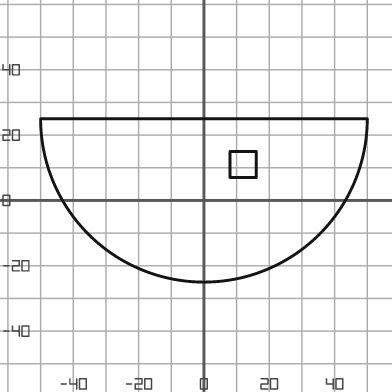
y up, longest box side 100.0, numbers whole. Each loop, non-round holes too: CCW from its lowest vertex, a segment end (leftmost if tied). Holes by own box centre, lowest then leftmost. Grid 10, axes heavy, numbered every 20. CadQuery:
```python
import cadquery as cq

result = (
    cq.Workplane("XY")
    .moveTo(-50.0, 25.0)
    .threePointArc((0.0, -25.0), (50.0, 25.0))
    .close()
    .moveTo(8.0, 7.0)
    .lineTo(16.0, 7.0)
    .lineTo(16.0, 15.0)
    .lineTo(8.0, 15.0)
    .close()
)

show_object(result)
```